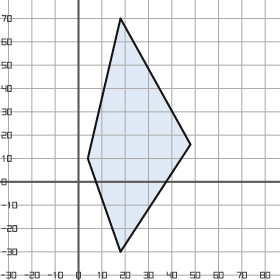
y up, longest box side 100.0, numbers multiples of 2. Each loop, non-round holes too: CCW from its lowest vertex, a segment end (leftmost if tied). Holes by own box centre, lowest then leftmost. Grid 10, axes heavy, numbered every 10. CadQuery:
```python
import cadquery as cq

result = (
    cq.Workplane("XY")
    .moveTo(18.0, -30.0)
    .lineTo(48.0, 16.0)
    .lineTo(18.0, 70.0)
    .lineTo(4.0, 10.0)
    .close()
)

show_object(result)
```